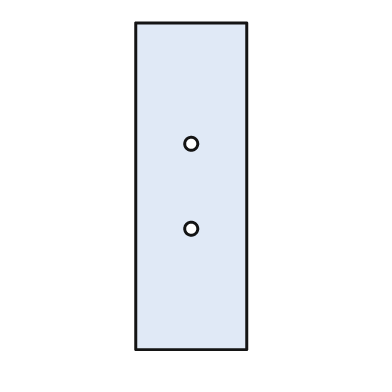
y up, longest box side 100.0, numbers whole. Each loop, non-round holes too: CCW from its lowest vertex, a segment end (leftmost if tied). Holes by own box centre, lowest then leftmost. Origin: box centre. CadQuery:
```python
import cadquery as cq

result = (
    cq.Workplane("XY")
    .moveTo(-17.0, -50.0)
    .lineTo(17.0, -50.0)
    .lineTo(17.0, 50.0)
    .lineTo(-17.0, 50.0)
    .close()
    .moveTo(0.0, -13.0)
    .circle(2.0)
    .moveTo(0.0, 13.0)
    .circle(2.0)
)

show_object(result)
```